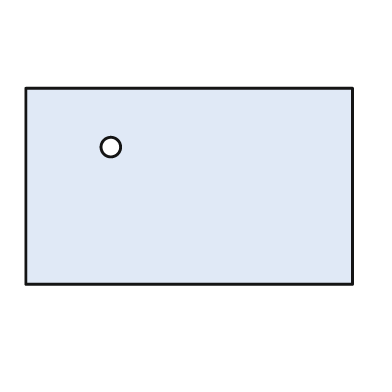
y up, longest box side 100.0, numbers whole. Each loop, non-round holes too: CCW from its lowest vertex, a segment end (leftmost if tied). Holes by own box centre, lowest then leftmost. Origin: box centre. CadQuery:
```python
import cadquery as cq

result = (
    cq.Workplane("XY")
    .moveTo(-50.0, -30.0)
    .lineTo(50.0, -30.0)
    .lineTo(50.0, 30.0)
    .lineTo(-50.0, 30.0)
    .close()
    .moveTo(-24.0, 12.0)
    .circle(3.0)
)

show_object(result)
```